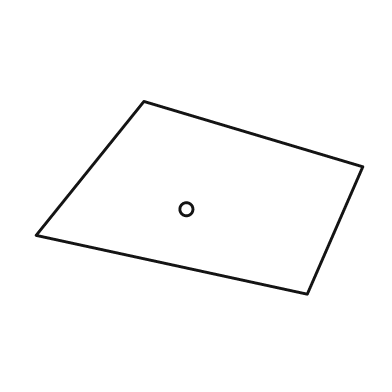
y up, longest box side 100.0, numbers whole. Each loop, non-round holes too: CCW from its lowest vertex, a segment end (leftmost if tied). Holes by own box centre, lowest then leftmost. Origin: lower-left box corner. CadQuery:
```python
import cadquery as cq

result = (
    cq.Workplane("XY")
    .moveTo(83.0, 0.0)
    .lineTo(100.0, 39.0)
    .lineTo(33.0, 59.0)
    .lineTo(0.0, 18.0)
    .close()
    .moveTo(46.0, 26.0)
    .circle(2.0)
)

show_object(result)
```